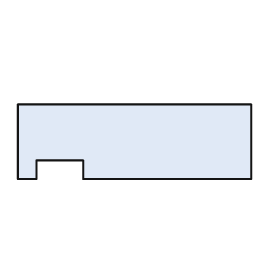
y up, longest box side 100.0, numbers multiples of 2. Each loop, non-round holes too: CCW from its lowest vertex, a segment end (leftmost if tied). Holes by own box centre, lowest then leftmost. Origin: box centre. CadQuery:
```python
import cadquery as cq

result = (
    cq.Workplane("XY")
    .moveTo(-50.0, -16.0)
    .lineTo(-42.0, -16.0)
    .lineTo(-42.0, -8.0)
    .lineTo(-22.0, -8.0)
    .lineTo(-22.0, -16.0)
    .lineTo(50.0, -16.0)
    .lineTo(50.0, 16.0)
    .lineTo(-50.0, 16.0)
    .close()
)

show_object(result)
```